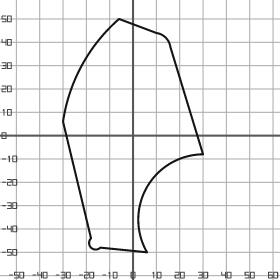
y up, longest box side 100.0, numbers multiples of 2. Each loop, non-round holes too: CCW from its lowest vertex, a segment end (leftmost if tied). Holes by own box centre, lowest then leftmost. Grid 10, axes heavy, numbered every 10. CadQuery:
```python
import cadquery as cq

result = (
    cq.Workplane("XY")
    .moveTo(6.0, -50.0)
    .threePointArc((6.0, -22.0), (30.0, -8.0))
    .lineTo(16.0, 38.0)
    .threePointArc((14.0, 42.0), (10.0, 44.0))
    .lineTo(-6.0, 50.0)
    .threePointArc((-22.0, 30.0), (-30.0, 6.0))
    .lineTo(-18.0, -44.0)
    .threePointArc((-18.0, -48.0), (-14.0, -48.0))
    .close()
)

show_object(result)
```